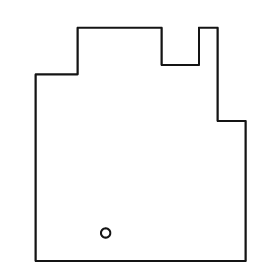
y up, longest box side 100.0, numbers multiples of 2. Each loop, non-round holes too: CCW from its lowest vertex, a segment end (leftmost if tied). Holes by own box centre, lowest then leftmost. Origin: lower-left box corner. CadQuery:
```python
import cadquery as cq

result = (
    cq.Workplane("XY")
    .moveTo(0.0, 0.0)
    .lineTo(90.0, 0.0)
    .lineTo(90.0, 60.0)
    .lineTo(78.0, 60.0)
    .lineTo(78.0, 100.0)
    .lineTo(70.0, 100.0)
    .lineTo(70.0, 84.0)
    .lineTo(54.0, 84.0)
    .lineTo(54.0, 100.0)
    .lineTo(18.0, 100.0)
    .lineTo(18.0, 80.0)
    .lineTo(0.0, 80.0)
    .close()
    .moveTo(30.0, 12.0)
    .circle(2.0)
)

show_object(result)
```